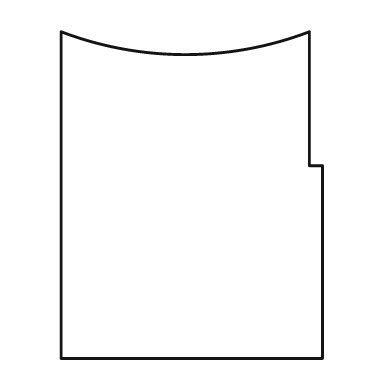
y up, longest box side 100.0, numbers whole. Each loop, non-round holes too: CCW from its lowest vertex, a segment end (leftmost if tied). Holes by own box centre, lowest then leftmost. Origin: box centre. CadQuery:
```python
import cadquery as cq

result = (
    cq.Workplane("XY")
    .moveTo(-40.0, -50.0)
    .lineTo(40.0, -50.0)
    .lineTo(40.0, 9.0)
    .lineTo(36.0, 9.0)
    .lineTo(36.0, 50.0)
    .threePointArc((-2.0, 43.0), (-40.0, 50.0))
    .close()
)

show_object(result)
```